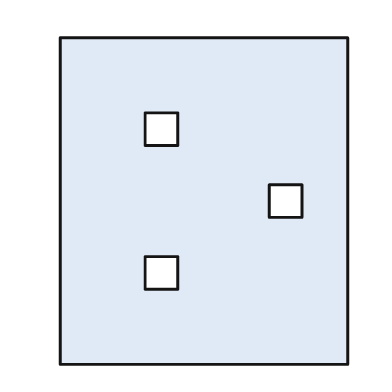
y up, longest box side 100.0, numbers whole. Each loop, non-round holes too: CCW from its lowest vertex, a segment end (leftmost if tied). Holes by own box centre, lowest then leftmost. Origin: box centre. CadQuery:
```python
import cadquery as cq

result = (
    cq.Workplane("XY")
    .moveTo(-44.0, -50.0)
    .lineTo(44.0, -50.0)
    .lineTo(44.0, 50.0)
    .lineTo(-44.0, 50.0)
    .close()
    .moveTo(-18.0, -27.0)
    .lineTo(-8.0, -27.0)
    .lineTo(-8.0, -17.0)
    .lineTo(-18.0, -17.0)
    .close()
    .moveTo(20.0, -5.0)
    .lineTo(30.0, -5.0)
    .lineTo(30.0, 5.0)
    .lineTo(20.0, 5.0)
    .close()
    .moveTo(-18.0, 17.0)
    .lineTo(-8.0, 17.0)
    .lineTo(-8.0, 27.0)
    .lineTo(-18.0, 27.0)
    .close()
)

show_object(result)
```